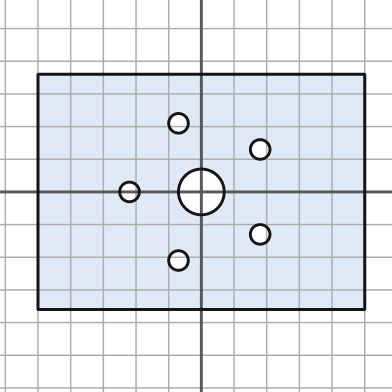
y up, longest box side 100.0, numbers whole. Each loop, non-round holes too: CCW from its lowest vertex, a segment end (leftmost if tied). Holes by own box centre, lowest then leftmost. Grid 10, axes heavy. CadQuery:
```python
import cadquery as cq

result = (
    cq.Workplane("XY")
    .moveTo(-50.0, -36.0)
    .lineTo(50.0, -36.0)
    .lineTo(50.0, 36.0)
    .lineTo(-50.0, 36.0)
    .close()
    .moveTo(-7.0, -21.0)
    .circle(3.0)
    .moveTo(18.0, -13.0)
    .circle(3.0)
    .moveTo(-22.0, 0.0)
    .circle(3.0)
    .moveTo(0.0, 0.0)
    .circle(7.0)
    .moveTo(18.0, 13.0)
    .circle(3.0)
    .moveTo(-7.0, 21.0)
    .circle(3.0)
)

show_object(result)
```